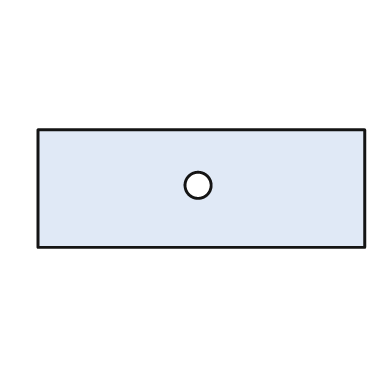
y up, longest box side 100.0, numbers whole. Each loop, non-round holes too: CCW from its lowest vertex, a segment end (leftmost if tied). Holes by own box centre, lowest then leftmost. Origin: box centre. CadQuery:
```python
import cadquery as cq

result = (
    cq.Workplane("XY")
    .moveTo(-50.0, -18.0)
    .lineTo(50.0, -18.0)
    .lineTo(50.0, 18.0)
    .lineTo(-50.0, 18.0)
    .close()
    .moveTo(-1.0, 1.0)
    .circle(4.0)
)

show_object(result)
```